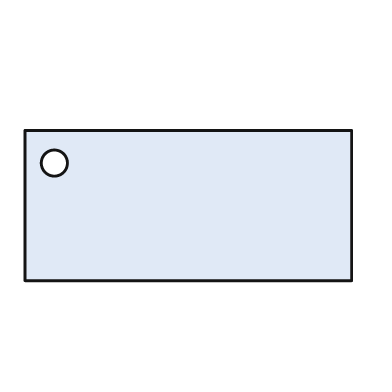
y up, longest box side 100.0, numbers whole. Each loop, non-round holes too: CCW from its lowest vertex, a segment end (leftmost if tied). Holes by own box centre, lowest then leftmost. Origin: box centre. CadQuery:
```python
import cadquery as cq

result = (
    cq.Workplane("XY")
    .moveTo(-50.0, -23.0)
    .lineTo(50.0, -23.0)
    .lineTo(50.0, 23.0)
    .lineTo(-50.0, 23.0)
    .close()
    .moveTo(-41.0, 13.0)
    .circle(4.0)
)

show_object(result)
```